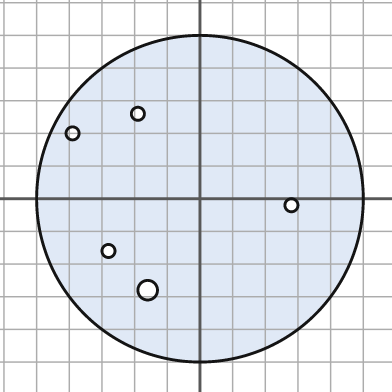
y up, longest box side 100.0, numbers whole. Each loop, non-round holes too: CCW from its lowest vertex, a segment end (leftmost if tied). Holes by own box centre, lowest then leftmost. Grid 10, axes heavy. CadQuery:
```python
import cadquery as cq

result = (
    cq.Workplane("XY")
    .moveTo(0.0, 0.0)
    .circle(50.0)
    .moveTo(-16.0, -28.0)
    .circle(3.0)
    .moveTo(-28.0, -16.0)
    .circle(2.0)
    .moveTo(28.0, -2.0)
    .circle(2.0)
    .moveTo(-39.0, 20.0)
    .circle(2.0)
    .moveTo(-19.0, 26.0)
    .circle(2.0)
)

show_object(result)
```